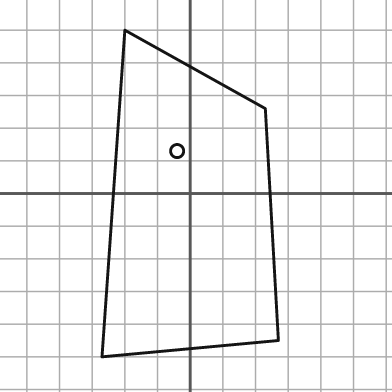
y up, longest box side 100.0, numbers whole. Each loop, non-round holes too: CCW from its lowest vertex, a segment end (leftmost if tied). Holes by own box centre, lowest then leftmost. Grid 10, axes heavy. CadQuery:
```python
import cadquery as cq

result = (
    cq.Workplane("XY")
    .moveTo(-27.0, -50.0)
    .lineTo(27.0, -45.0)
    .lineTo(23.0, 26.0)
    .lineTo(-20.0, 50.0)
    .close()
    .moveTo(-4.0, 13.0)
    .circle(2.0)
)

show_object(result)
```